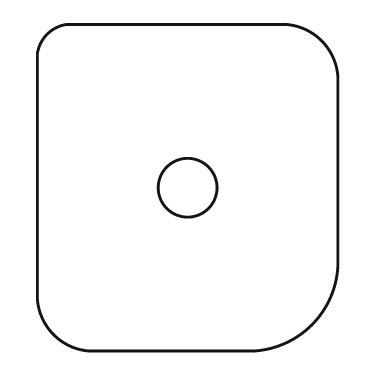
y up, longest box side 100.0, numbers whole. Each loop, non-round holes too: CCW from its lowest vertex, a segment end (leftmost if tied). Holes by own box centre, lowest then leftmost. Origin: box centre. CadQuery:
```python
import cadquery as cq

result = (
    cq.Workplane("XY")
    .moveTo(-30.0, -50.0)
    .lineTo(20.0, -50.0)
    .threePointArc((38.0, -42.0), (46.0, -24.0))
    .lineTo(46.0, 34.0)
    .threePointArc((41.0, 45.0), (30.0, 50.0))
    .lineTo(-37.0, 50.0)
    .threePointArc((-43.0, 47.0), (-46.0, 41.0))
    .lineTo(-46.0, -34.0)
    .threePointArc((-41.0, -45.0), (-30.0, -50.0))
    .close()
    .moveTo(0.0, 0.0)
    .circle(9.0)
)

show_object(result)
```